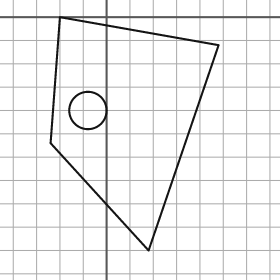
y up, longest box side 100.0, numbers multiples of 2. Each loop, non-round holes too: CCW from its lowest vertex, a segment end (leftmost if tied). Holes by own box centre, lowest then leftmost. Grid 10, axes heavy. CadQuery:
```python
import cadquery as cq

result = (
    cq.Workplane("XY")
    .moveTo(18.0, -100.0)
    .lineTo(48.0, -12.0)
    .lineTo(-20.0, 0.0)
    .lineTo(-24.0, -54.0)
    .close()
    .moveTo(-8.0, -40.0)
    .circle(8.0)
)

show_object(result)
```